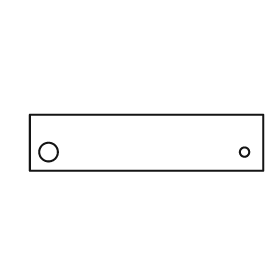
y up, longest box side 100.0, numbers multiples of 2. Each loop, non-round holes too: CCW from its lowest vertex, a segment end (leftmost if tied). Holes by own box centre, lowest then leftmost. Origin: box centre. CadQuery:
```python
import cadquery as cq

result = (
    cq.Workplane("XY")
    .moveTo(-50.0, -12.0)
    .lineTo(50.0, -12.0)
    .lineTo(50.0, 12.0)
    .lineTo(-50.0, 12.0)
    .close()
    .moveTo(-42.0, -4.0)
    .circle(4.0)
    .moveTo(42.0, -4.0)
    .circle(2.0)
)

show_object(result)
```